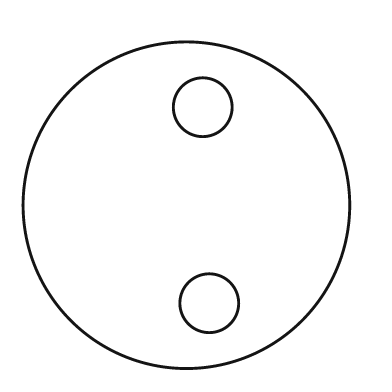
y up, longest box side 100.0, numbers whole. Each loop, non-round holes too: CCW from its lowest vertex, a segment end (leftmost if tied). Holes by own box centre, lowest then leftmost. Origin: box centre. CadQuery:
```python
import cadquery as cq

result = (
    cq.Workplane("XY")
    .moveTo(0.0, 0.0)
    .circle(50.0)
    .moveTo(7.0, -30.0)
    .circle(9.0)
    .moveTo(5.0, 30.0)
    .circle(9.0)
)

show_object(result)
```